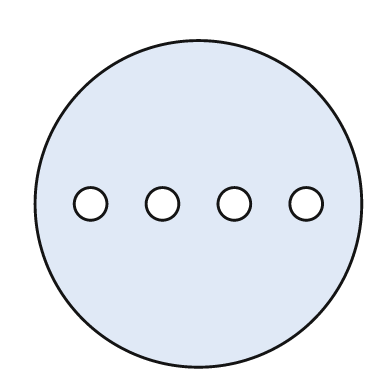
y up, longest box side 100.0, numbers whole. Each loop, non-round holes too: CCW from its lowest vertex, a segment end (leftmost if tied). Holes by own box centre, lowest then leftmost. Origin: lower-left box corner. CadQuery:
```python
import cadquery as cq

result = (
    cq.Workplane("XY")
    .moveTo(50.0, 50.0)
    .circle(50.0)
    .moveTo(17.0, 50.0)
    .circle(5.0)
    .moveTo(39.0, 50.0)
    .circle(5.0)
    .moveTo(61.0, 50.0)
    .circle(5.0)
    .moveTo(83.0, 50.0)
    .circle(5.0)
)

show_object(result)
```